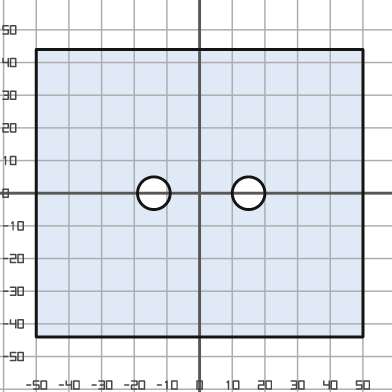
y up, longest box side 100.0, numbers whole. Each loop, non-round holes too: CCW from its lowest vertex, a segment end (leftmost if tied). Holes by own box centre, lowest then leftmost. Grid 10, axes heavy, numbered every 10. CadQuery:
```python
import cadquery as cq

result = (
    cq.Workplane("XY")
    .moveTo(-50.0, -44.0)
    .lineTo(50.0, -44.0)
    .lineTo(50.0, 44.0)
    .lineTo(-50.0, 44.0)
    .close()
    .moveTo(-14.0, 0.0)
    .circle(5.0)
    .moveTo(15.0, 0.0)
    .circle(5.0)
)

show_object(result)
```